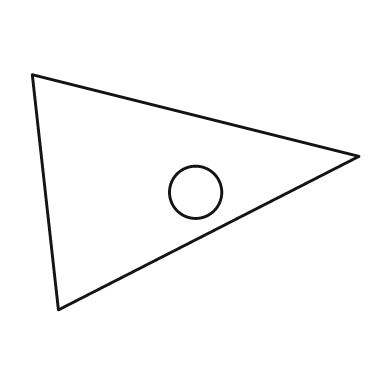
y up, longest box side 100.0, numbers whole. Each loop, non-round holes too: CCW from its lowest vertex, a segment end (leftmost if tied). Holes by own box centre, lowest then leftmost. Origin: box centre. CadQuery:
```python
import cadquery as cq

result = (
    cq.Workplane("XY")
    .moveTo(-42.0, -36.0)
    .lineTo(50.0, 11.0)
    .lineTo(-50.0, 36.0)
    .close()
    .moveTo(0.0, 0.0)
    .circle(8.0)
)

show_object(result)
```